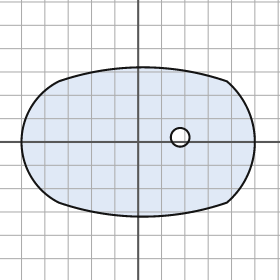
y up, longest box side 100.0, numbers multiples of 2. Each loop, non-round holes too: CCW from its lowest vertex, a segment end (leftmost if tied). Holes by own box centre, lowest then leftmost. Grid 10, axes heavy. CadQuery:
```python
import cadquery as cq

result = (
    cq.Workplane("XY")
    .moveTo(-34.0, -26.0)
    .threePointArc((2.0, -32.0), (38.0, -26.0))
    .threePointArc((50.0, 0.0), (38.0, 26.0))
    .threePointArc((2.0, 32.0), (-34.0, 26.0))
    .threePointArc((-50.0, 0.0), (-34.0, -26.0))
    .close()
    .moveTo(18.0, 2.0)
    .circle(4.0)
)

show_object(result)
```